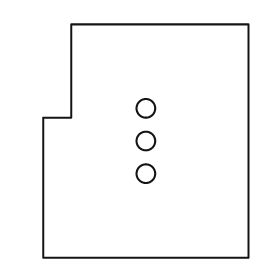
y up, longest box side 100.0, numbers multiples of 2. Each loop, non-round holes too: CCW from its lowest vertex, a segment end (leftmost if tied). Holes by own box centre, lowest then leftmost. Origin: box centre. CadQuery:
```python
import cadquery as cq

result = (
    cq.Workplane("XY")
    .moveTo(-44.0, -50.0)
    .lineTo(44.0, -50.0)
    .lineTo(44.0, 50.0)
    .lineTo(-32.0, 50.0)
    .lineTo(-32.0, 10.0)
    .lineTo(-44.0, 10.0)
    .close()
    .moveTo(0.0, -14.0)
    .circle(4.0)
    .moveTo(0.0, 0.0)
    .circle(4.0)
    .moveTo(0.0, 14.0)
    .circle(4.0)
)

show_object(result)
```